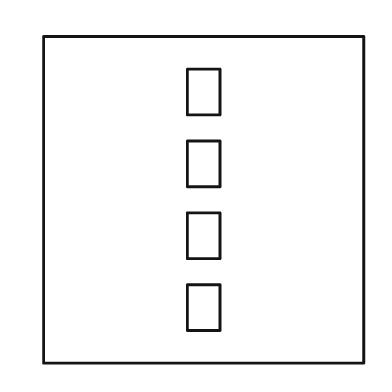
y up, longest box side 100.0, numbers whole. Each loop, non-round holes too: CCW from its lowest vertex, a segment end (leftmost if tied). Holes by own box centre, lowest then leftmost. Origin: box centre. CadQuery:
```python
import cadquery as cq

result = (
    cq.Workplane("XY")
    .moveTo(-49.0, -50.0)
    .lineTo(49.0, -50.0)
    .lineTo(49.0, 50.0)
    .lineTo(-49.0, 50.0)
    .close()
    .moveTo(-5.0, -40.0)
    .lineTo(5.0, -40.0)
    .lineTo(5.0, -26.0)
    .lineTo(-5.0, -26.0)
    .close()
    .moveTo(-5.0, -18.0)
    .lineTo(5.0, -18.0)
    .lineTo(5.0, -4.0)
    .lineTo(-5.0, -4.0)
    .close()
    .moveTo(-5.0, 4.0)
    .lineTo(5.0, 4.0)
    .lineTo(5.0, 18.0)
    .lineTo(-5.0, 18.0)
    .close()
    .moveTo(-5.0, 26.0)
    .lineTo(5.0, 26.0)
    .lineTo(5.0, 40.0)
    .lineTo(-5.0, 40.0)
    .close()
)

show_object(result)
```